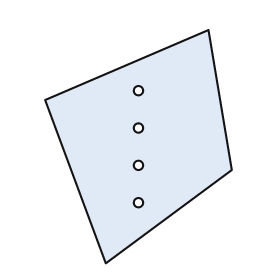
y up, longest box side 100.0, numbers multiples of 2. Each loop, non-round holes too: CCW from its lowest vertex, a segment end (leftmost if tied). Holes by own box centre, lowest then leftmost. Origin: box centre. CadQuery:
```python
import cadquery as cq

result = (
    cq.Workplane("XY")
    .moveTo(-14.0, -50.0)
    .lineTo(40.0, -10.0)
    .lineTo(30.0, 50.0)
    .lineTo(-40.0, 20.0)
    .close()
    .moveTo(0.0, -24.0)
    .circle(2.0)
    .moveTo(0.0, -8.0)
    .circle(2.0)
    .moveTo(0.0, 8.0)
    .circle(2.0)
    .moveTo(0.0, 24.0)
    .circle(2.0)
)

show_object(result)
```